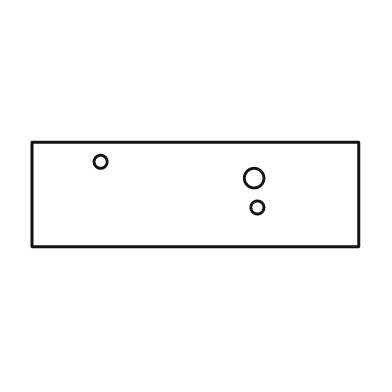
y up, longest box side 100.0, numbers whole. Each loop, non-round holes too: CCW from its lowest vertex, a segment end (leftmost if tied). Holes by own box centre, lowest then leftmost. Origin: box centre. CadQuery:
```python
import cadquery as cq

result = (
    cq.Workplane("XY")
    .moveTo(-50.0, -16.0)
    .lineTo(50.0, -16.0)
    .lineTo(50.0, 16.0)
    .lineTo(-50.0, 16.0)
    .close()
    .moveTo(19.0, -4.0)
    .circle(2.0)
    .moveTo(18.0, 5.0)
    .circle(3.0)
    .moveTo(-29.0, 10.0)
    .circle(2.0)
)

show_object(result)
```